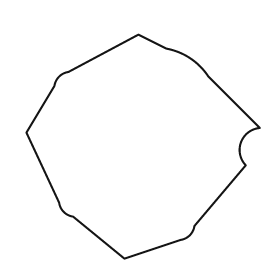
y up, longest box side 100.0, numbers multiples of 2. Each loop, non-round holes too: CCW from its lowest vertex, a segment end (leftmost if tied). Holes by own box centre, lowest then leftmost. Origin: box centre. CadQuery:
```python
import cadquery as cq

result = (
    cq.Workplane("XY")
    .moveTo(-8.0, -48.0)
    .lineTo(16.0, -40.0)
    .threePointArc((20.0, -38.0), (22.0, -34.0))
    .lineTo(44.0, -8.0)
    .threePointArc((42.0, 2.0), (50.0, 8.0))
    .lineTo(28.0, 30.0)
    .threePointArc((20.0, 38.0), (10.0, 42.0))
    .lineTo(-2.0, 48.0)
    .lineTo(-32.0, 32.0)
    .threePointArc((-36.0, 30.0), (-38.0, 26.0))
    .lineTo(-50.0, 6.0)
    .lineTo(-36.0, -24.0)
    .threePointArc((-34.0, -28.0), (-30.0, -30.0))
    .close()
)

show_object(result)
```